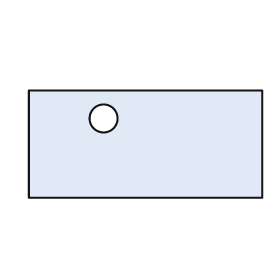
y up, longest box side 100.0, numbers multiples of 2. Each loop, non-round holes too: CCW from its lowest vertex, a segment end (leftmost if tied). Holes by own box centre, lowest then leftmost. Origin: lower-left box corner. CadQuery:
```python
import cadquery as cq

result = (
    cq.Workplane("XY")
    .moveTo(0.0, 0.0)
    .lineTo(100.0, 0.0)
    .lineTo(100.0, 46.0)
    .lineTo(0.0, 46.0)
    .close()
    .moveTo(32.0, 34.0)
    .circle(6.0)
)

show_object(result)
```